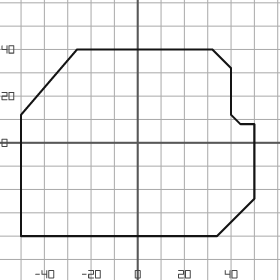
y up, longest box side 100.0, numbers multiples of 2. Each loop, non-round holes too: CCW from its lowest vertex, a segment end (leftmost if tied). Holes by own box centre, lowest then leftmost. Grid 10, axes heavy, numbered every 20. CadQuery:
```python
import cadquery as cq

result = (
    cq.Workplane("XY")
    .moveTo(-50.0, -40.0)
    .lineTo(34.0, -40.0)
    .lineTo(50.0, -24.0)
    .lineTo(50.0, 8.0)
    .lineTo(44.0, 8.0)
    .lineTo(40.0, 12.0)
    .lineTo(40.0, 32.0)
    .lineTo(32.0, 40.0)
    .lineTo(-26.0, 40.0)
    .lineTo(-50.0, 12.0)
    .close()
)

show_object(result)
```